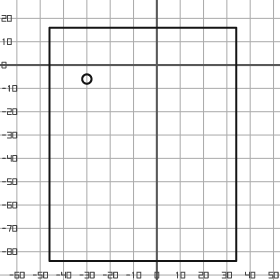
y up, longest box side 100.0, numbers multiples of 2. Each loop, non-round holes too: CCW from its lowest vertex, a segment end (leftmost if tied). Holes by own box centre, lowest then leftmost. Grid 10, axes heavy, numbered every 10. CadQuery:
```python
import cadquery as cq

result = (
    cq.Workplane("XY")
    .moveTo(-46.0, -84.0)
    .lineTo(34.0, -84.0)
    .lineTo(34.0, 16.0)
    .lineTo(-46.0, 16.0)
    .close()
    .moveTo(-30.0, -6.0)
    .circle(2.0)
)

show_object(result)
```